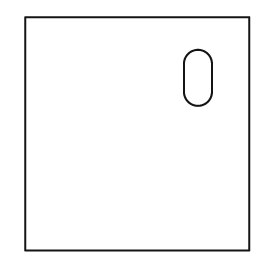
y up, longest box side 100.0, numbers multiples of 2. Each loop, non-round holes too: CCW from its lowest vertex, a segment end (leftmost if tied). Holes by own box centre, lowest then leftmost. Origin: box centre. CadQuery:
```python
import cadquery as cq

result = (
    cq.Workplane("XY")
    .moveTo(-48.0, -50.0)
    .lineTo(48.0, -50.0)
    .lineTo(48.0, 50.0)
    .lineTo(-48.0, 50.0)
    .close()
    .moveTo(20.0, 18.0)
    .threePointArc((26.0, 12.0), (32.0, 18.0))
    .lineTo(32.0, 30.0)
    .threePointArc((26.0, 36.0), (20.0, 30.0))
    .close()
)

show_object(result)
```